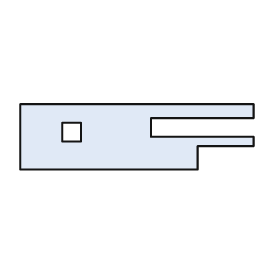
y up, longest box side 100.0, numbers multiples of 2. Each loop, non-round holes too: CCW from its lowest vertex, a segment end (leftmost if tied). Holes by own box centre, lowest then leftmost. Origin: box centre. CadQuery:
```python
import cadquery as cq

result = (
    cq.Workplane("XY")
    .moveTo(-50.0, -14.0)
    .lineTo(26.0, -14.0)
    .lineTo(26.0, -4.0)
    .lineTo(50.0, -4.0)
    .lineTo(50.0, 0.0)
    .lineTo(6.0, 0.0)
    .lineTo(6.0, 8.0)
    .lineTo(50.0, 8.0)
    .lineTo(50.0, 14.0)
    .lineTo(-50.0, 14.0)
    .close()
    .moveTo(-32.0, -2.0)
    .lineTo(-24.0, -2.0)
    .lineTo(-24.0, 6.0)
    .lineTo(-32.0, 6.0)
    .close()
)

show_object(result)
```